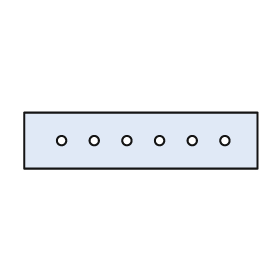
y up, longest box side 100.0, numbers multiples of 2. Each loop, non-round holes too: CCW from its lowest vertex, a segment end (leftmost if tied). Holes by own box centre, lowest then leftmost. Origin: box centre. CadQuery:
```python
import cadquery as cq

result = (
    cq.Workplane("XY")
    .moveTo(-50.0, -12.0)
    .lineTo(50.0, -12.0)
    .lineTo(50.0, 12.0)
    .lineTo(-50.0, 12.0)
    .close()
    .moveTo(-34.0, 0.0)
    .circle(2.0)
    .moveTo(-20.0, 0.0)
    .circle(2.0)
    .moveTo(-6.0, 0.0)
    .circle(2.0)
    .moveTo(8.0, 0.0)
    .circle(2.0)
    .moveTo(22.0, 0.0)
    .circle(2.0)
    .moveTo(36.0, 0.0)
    .circle(2.0)
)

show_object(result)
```